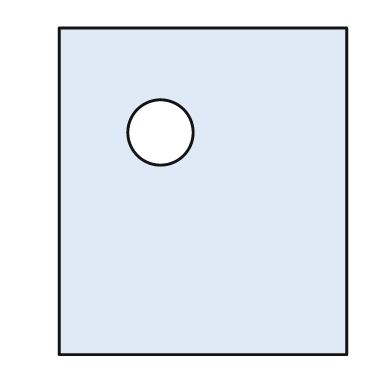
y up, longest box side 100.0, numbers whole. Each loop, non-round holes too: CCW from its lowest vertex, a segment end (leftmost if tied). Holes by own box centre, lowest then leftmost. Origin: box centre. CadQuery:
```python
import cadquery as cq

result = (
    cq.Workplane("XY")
    .moveTo(-44.0, -50.0)
    .lineTo(44.0, -50.0)
    .lineTo(44.0, 50.0)
    .lineTo(-44.0, 50.0)
    .close()
    .moveTo(-13.0, 18.0)
    .circle(10.0)
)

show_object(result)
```